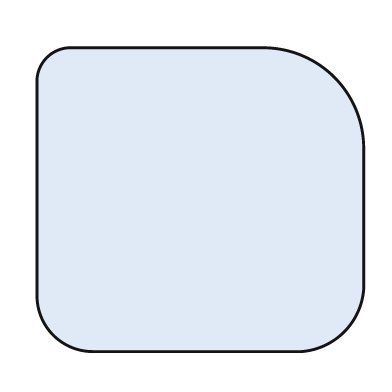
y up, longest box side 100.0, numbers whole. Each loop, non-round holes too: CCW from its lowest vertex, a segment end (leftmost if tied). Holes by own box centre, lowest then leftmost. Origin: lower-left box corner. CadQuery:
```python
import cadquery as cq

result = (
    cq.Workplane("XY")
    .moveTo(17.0, 0.0)
    .lineTo(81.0, 0.0)
    .threePointArc((94.0, 6.0), (100.0, 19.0))
    .lineTo(100.0, 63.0)
    .threePointArc((91.0, 84.0), (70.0, 93.0))
    .lineTo(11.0, 93.0)
    .threePointArc((3.0, 90.0), (0.0, 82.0))
    .lineTo(0.0, 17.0)
    .threePointArc((5.0, 5.0), (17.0, 0.0))
    .close()
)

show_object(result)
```